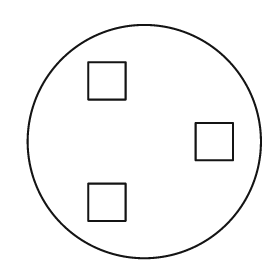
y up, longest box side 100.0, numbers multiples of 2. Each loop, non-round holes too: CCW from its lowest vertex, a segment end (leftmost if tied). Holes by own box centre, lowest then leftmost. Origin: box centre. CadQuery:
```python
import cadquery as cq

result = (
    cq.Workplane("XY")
    .moveTo(0.0, 0.0)
    .circle(50.0)
    .moveTo(-24.0, -34.0)
    .lineTo(-8.0, -34.0)
    .lineTo(-8.0, -18.0)
    .lineTo(-24.0, -18.0)
    .close()
    .moveTo(22.0, -8.0)
    .lineTo(38.0, -8.0)
    .lineTo(38.0, 8.0)
    .lineTo(22.0, 8.0)
    .close()
    .moveTo(-24.0, 18.0)
    .lineTo(-8.0, 18.0)
    .lineTo(-8.0, 34.0)
    .lineTo(-24.0, 34.0)
    .close()
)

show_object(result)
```